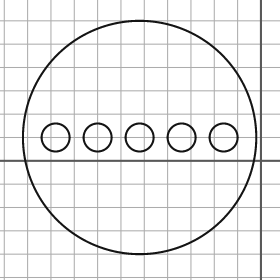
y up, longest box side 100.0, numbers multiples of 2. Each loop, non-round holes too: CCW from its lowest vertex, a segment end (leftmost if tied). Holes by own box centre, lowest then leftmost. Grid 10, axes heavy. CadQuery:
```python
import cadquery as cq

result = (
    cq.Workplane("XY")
    .moveTo(-52.0, 10.0)
    .circle(50.0)
    .moveTo(-88.0, 10.0)
    .circle(6.0)
    .moveTo(-70.0, 10.0)
    .circle(6.0)
    .moveTo(-52.0, 10.0)
    .circle(6.0)
    .moveTo(-34.0, 10.0)
    .circle(6.0)
    .moveTo(-16.0, 10.0)
    .circle(6.0)
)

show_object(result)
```